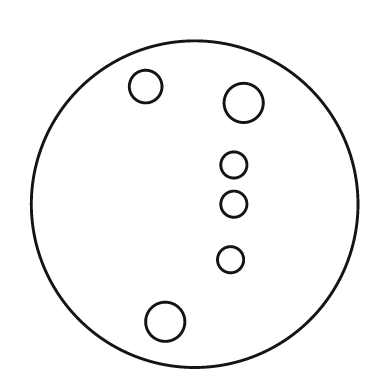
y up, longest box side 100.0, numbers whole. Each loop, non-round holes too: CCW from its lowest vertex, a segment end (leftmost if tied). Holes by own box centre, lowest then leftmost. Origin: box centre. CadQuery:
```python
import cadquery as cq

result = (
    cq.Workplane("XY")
    .moveTo(0.0, 0.0)
    .circle(50.0)
    .moveTo(-9.0, -36.0)
    .circle(6.0)
    .moveTo(11.0, -17.0)
    .circle(4.0)
    .moveTo(12.0, 0.0)
    .circle(4.0)
    .moveTo(12.0, 12.0)
    .circle(4.0)
    .moveTo(15.0, 31.0)
    .circle(6.0)
    .moveTo(-15.0, 36.0)
    .circle(5.0)
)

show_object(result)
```